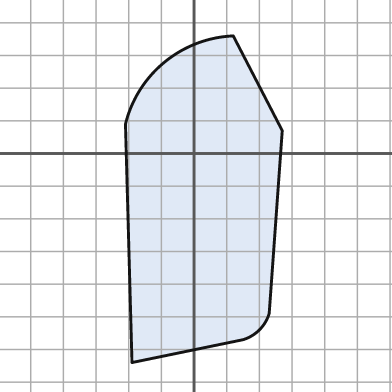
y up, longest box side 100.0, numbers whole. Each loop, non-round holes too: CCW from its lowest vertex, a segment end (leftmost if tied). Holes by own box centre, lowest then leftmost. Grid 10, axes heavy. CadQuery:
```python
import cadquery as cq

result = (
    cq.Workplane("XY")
    .moveTo(-19.0, -64.0)
    .lineTo(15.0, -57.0)
    .threePointArc((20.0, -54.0), (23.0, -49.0))
    .lineTo(27.0, 7.0)
    .lineTo(12.0, 36.0)
    .threePointArc((-9.0, 28.0), (-21.0, 9.0))
    .close()
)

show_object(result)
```